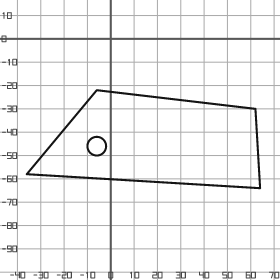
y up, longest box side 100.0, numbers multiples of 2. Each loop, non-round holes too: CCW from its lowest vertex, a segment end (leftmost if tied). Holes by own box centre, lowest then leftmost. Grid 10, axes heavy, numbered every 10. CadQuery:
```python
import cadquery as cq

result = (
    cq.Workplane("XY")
    .moveTo(64.0, -64.0)
    .lineTo(62.0, -30.0)
    .lineTo(-6.0, -22.0)
    .lineTo(-36.0, -58.0)
    .close()
    .moveTo(-6.0, -46.0)
    .circle(4.0)
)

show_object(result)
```